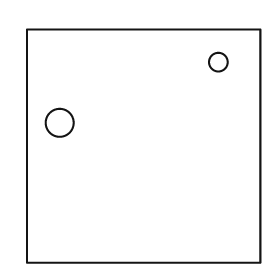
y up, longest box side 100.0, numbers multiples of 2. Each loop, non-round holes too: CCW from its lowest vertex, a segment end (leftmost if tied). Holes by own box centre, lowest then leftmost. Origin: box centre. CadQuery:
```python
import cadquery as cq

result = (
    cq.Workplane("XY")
    .moveTo(-50.0, -50.0)
    .lineTo(50.0, -50.0)
    .lineTo(50.0, 50.0)
    .lineTo(-50.0, 50.0)
    .close()
    .moveTo(-36.0, 10.0)
    .circle(6.0)
    .moveTo(32.0, 36.0)
    .circle(4.0)
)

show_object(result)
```